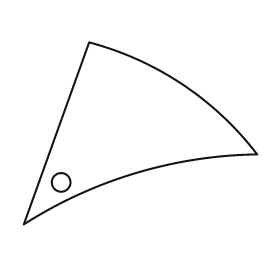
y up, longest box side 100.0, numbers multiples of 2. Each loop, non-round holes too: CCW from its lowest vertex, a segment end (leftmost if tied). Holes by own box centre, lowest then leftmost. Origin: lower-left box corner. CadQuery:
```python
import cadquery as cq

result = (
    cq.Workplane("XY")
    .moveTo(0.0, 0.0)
    .threePointArc((48.0, 22.0), (100.0, 30.0))
    .threePointArc((68.0, 60.0), (28.0, 78.0))
    .close()
    .moveTo(16.0, 18.0)
    .circle(4.0)
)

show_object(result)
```